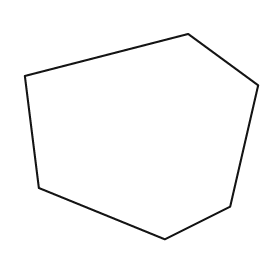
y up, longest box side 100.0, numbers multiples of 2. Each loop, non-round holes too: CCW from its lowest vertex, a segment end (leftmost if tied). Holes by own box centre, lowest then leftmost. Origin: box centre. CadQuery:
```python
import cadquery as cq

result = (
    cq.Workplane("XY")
    .moveTo(10.0, -44.0)
    .lineTo(38.0, -30.0)
    .lineTo(50.0, 22.0)
    .lineTo(20.0, 44.0)
    .lineTo(-50.0, 26.0)
    .lineTo(-44.0, -22.0)
    .close()
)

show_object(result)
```